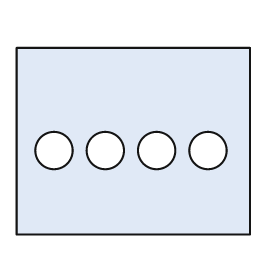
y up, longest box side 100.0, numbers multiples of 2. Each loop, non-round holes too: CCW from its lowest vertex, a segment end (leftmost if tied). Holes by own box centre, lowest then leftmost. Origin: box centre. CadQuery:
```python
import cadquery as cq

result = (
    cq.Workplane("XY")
    .moveTo(-50.0, -40.0)
    .lineTo(50.0, -40.0)
    .lineTo(50.0, 40.0)
    .lineTo(-50.0, 40.0)
    .close()
    .moveTo(-34.0, -4.0)
    .circle(8.0)
    .moveTo(-12.0, -4.0)
    .circle(8.0)
    .moveTo(10.0, -4.0)
    .circle(8.0)
    .moveTo(32.0, -4.0)
    .circle(8.0)
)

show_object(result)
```